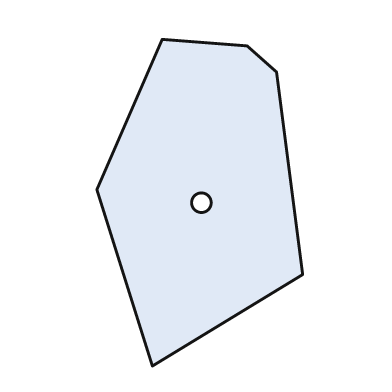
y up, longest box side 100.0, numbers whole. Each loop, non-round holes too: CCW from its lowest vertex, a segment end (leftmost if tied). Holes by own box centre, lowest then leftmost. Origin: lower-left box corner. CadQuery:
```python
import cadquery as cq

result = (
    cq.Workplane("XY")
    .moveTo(17.0, 0.0)
    .lineTo(63.0, 28.0)
    .lineTo(55.0, 90.0)
    .lineTo(46.0, 98.0)
    .lineTo(20.0, 100.0)
    .lineTo(0.0, 54.0)
    .close()
    .moveTo(32.0, 50.0)
    .circle(3.0)
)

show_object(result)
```